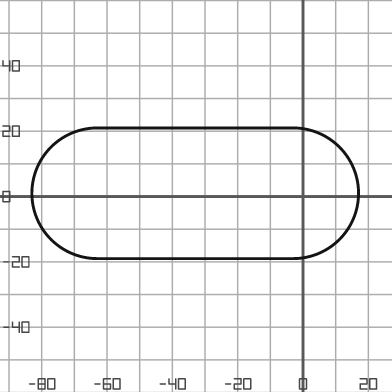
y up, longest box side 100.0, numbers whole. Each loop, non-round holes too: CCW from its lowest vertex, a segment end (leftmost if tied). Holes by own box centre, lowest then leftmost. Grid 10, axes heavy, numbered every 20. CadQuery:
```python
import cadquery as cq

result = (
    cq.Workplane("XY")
    .moveTo(-63.0, -19.0)
    .lineTo(-3.0, -19.0)
    .threePointArc((17.0, 1.0), (-3.0, 21.0))
    .lineTo(-63.0, 21.0)
    .threePointArc((-83.0, 1.0), (-63.0, -19.0))
    .close()
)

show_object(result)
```